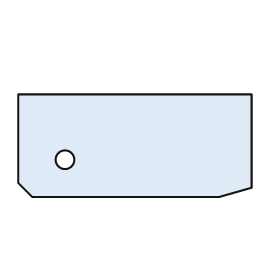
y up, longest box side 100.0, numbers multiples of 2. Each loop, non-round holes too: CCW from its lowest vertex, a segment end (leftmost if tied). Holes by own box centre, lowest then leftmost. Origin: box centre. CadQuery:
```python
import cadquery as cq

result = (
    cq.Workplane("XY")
    .moveTo(-44.0, -22.0)
    .lineTo(36.0, -22.0)
    .lineTo(50.0, -18.0)
    .lineTo(50.0, 22.0)
    .lineTo(-50.0, 22.0)
    .lineTo(-50.0, -16.0)
    .close()
    .moveTo(-30.0, -6.0)
    .circle(4.0)
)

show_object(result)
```